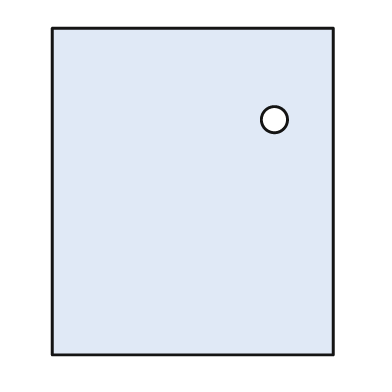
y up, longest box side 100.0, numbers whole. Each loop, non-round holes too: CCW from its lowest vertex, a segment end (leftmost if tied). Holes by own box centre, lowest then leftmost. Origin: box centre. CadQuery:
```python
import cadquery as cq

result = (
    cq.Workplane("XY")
    .moveTo(-43.0, -50.0)
    .lineTo(43.0, -50.0)
    .lineTo(43.0, 50.0)
    .lineTo(-43.0, 50.0)
    .close()
    .moveTo(25.0, 22.0)
    .circle(4.0)
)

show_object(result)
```